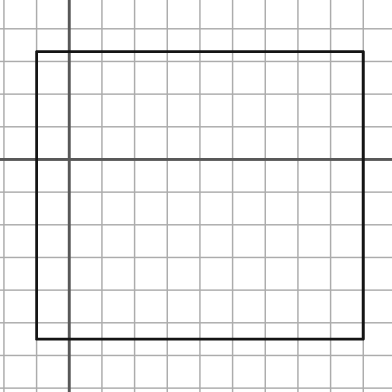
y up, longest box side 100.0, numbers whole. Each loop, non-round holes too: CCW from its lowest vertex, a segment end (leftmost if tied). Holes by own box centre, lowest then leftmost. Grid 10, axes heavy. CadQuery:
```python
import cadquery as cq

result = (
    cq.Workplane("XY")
    .moveTo(-10.0, -55.0)
    .lineTo(90.0, -55.0)
    .lineTo(90.0, 33.0)
    .lineTo(-10.0, 33.0)
    .close()
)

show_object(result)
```